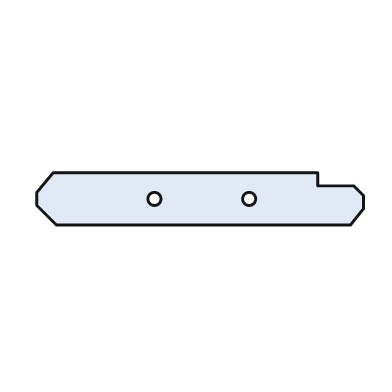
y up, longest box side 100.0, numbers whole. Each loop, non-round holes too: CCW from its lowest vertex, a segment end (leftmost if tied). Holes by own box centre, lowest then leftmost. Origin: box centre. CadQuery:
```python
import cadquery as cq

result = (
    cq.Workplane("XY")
    .moveTo(-44.0, -8.0)
    .lineTo(46.0, -8.0)
    .lineTo(50.0, -3.0)
    .lineTo(50.0, 1.0)
    .lineTo(47.0, 4.0)
    .lineTo(36.0, 4.0)
    .lineTo(36.0, 8.0)
    .lineTo(-45.0, 8.0)
    .lineTo(-50.0, 2.0)
    .lineTo(-50.0, -2.0)
    .close()
    .moveTo(-14.0, 0.0)
    .circle(2.0)
    .moveTo(15.0, 0.0)
    .circle(2.0)
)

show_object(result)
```